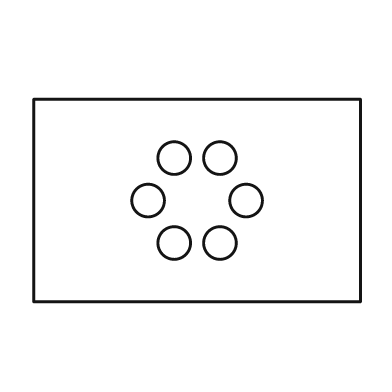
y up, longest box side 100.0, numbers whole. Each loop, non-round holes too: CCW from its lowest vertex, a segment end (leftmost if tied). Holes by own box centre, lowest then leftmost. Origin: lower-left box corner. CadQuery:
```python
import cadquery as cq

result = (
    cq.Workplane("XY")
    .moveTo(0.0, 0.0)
    .lineTo(100.0, 0.0)
    .lineTo(100.0, 62.0)
    .lineTo(0.0, 62.0)
    .close()
    .moveTo(43.0, 18.0)
    .circle(5.0)
    .moveTo(57.0, 18.0)
    .circle(5.0)
    .moveTo(35.0, 31.0)
    .circle(5.0)
    .moveTo(65.0, 31.0)
    .circle(5.0)
    .moveTo(43.0, 44.0)
    .circle(5.0)
    .moveTo(57.0, 44.0)
    .circle(5.0)
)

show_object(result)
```